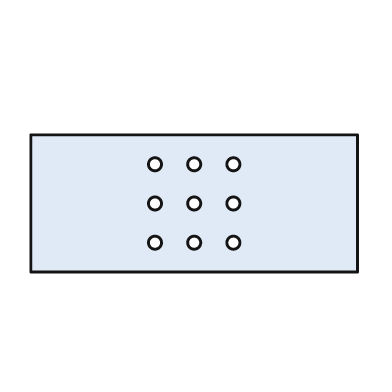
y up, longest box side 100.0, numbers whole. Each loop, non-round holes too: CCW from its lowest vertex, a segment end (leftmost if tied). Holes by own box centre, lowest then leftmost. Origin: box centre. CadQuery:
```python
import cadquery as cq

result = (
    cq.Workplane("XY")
    .moveTo(-50.0, -21.0)
    .lineTo(50.0, -21.0)
    .lineTo(50.0, 21.0)
    .lineTo(-50.0, 21.0)
    .close()
    .moveTo(-12.0, -12.0)
    .circle(2.0)
    .moveTo(0.0, -12.0)
    .circle(2.0)
    .moveTo(12.0, -12.0)
    .circle(2.0)
    .moveTo(-12.0, 0.0)
    .circle(2.0)
    .moveTo(0.0, 0.0)
    .circle(2.0)
    .moveTo(12.0, 0.0)
    .circle(2.0)
    .moveTo(-12.0, 12.0)
    .circle(2.0)
    .moveTo(0.0, 12.0)
    .circle(2.0)
    .moveTo(12.0, 12.0)
    .circle(2.0)
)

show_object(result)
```